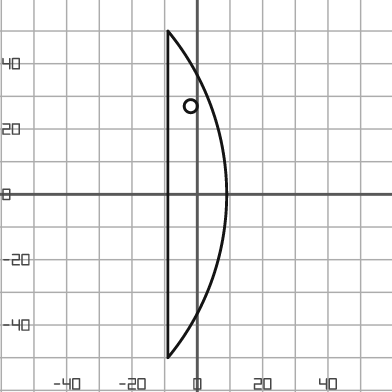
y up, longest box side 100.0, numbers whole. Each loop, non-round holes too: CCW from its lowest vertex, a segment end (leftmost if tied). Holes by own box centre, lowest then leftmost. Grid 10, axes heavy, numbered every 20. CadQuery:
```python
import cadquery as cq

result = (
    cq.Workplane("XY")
    .moveTo(-9.0, -50.0)
    .threePointArc((9.0, 0.0), (-9.0, 50.0))
    .close()
    .moveTo(-2.0, 27.0)
    .circle(2.0)
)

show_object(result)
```